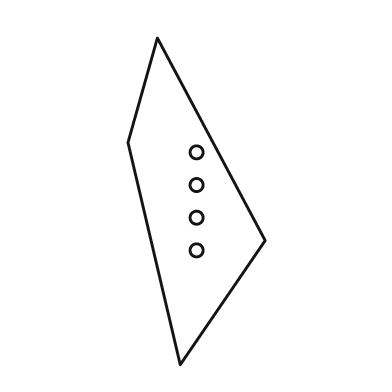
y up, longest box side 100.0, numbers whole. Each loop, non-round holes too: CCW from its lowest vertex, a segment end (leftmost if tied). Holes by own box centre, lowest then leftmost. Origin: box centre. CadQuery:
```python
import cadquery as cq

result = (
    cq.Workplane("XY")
    .moveTo(-5.0, -50.0)
    .lineTo(21.0, -12.0)
    .lineTo(-12.0, 50.0)
    .lineTo(-21.0, 18.0)
    .close()
    .moveTo(0.0, -15.0)
    .circle(2.0)
    .moveTo(0.0, -5.0)
    .circle(2.0)
    .moveTo(0.0, 5.0)
    .circle(2.0)
    .moveTo(0.0, 15.0)
    .circle(2.0)
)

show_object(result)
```